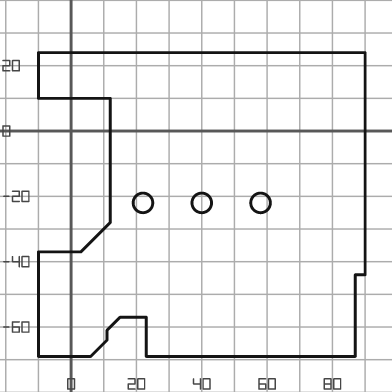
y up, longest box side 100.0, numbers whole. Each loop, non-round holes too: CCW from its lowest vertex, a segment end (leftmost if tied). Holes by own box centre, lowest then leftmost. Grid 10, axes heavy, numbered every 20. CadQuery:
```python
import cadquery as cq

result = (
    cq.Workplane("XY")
    .moveTo(-10.0, -69.0)
    .lineTo(6.0, -69.0)
    .lineTo(11.0, -64.0)
    .lineTo(11.0, -61.0)
    .lineTo(15.0, -57.0)
    .lineTo(23.0, -57.0)
    .lineTo(23.0, -69.0)
    .lineTo(87.0, -69.0)
    .lineTo(87.0, -44.0)
    .lineTo(90.0, -44.0)
    .lineTo(90.0, 24.0)
    .lineTo(-10.0, 24.0)
    .lineTo(-10.0, 10.0)
    .lineTo(12.0, 10.0)
    .lineTo(12.0, -28.0)
    .lineTo(3.0, -37.0)
    .lineTo(-10.0, -37.0)
    .close()
    .moveTo(22.0, -22.0)
    .circle(3.0)
    .moveTo(40.0, -22.0)
    .circle(3.0)
    .moveTo(58.0, -22.0)
    .circle(3.0)
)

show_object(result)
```